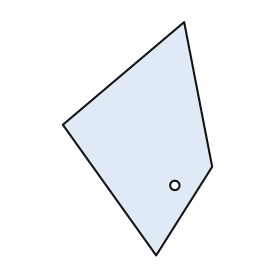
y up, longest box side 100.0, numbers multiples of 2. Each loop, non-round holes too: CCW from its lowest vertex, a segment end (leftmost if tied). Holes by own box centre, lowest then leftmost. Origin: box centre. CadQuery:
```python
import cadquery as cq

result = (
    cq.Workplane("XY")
    .moveTo(8.0, -50.0)
    .lineTo(32.0, -12.0)
    .lineTo(20.0, 50.0)
    .lineTo(-32.0, 6.0)
    .close()
    .moveTo(16.0, -20.0)
    .circle(2.0)
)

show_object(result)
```